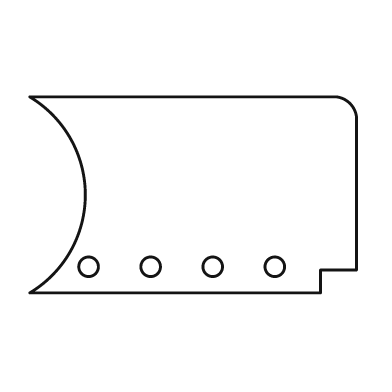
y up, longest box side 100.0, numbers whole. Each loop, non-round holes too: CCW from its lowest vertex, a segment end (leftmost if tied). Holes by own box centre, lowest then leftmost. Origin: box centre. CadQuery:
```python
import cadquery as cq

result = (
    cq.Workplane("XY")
    .moveTo(-50.0, -30.0)
    .lineTo(39.0, -30.0)
    .lineTo(39.0, -23.0)
    .lineTo(50.0, -23.0)
    .lineTo(50.0, 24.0)
    .threePointArc((48.0, 28.0), (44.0, 30.0))
    .lineTo(-50.0, 30.0)
    .threePointArc((-33.0, 0.0), (-50.0, -30.0))
    .close()
    .moveTo(-32.0, -22.0)
    .circle(3.0)
    .moveTo(-13.0, -22.0)
    .circle(3.0)
    .moveTo(6.0, -22.0)
    .circle(3.0)
    .moveTo(25.0, -22.0)
    .circle(3.0)
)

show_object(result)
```